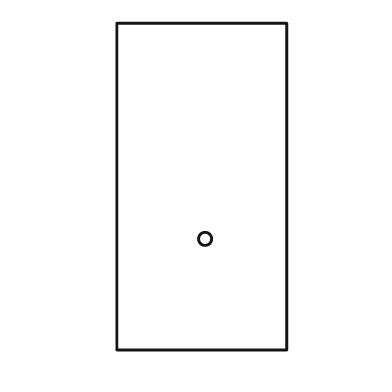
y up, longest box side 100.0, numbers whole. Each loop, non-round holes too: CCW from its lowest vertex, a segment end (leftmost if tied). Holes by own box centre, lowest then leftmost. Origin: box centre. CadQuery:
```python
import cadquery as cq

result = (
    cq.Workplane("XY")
    .moveTo(-26.0, -50.0)
    .lineTo(26.0, -50.0)
    .lineTo(26.0, 50.0)
    .lineTo(-26.0, 50.0)
    .close()
    .moveTo(1.0, -16.0)
    .circle(2.0)
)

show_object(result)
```